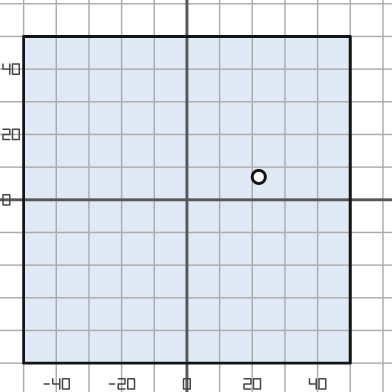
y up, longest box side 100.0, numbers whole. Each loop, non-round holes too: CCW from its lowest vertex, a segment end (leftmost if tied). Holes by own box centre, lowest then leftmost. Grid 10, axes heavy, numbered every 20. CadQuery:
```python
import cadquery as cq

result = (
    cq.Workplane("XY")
    .moveTo(-50.0, -50.0)
    .lineTo(50.0, -50.0)
    .lineTo(50.0, 50.0)
    .lineTo(-50.0, 50.0)
    .close()
    .moveTo(22.0, 7.0)
    .circle(2.0)
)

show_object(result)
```